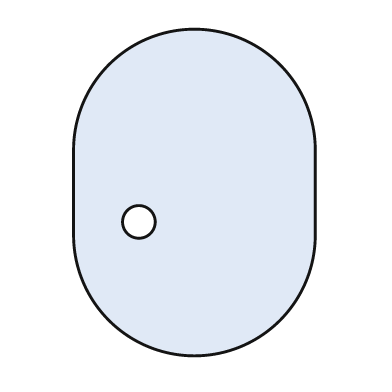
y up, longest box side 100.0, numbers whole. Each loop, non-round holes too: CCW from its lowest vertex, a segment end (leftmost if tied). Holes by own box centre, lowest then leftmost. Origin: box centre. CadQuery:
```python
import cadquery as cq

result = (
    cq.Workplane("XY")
    .moveTo(-37.0, -13.0)
    .threePointArc((0.0, -50.0), (37.0, -13.0))
    .lineTo(37.0, 13.0)
    .threePointArc((0.0, 50.0), (-37.0, 13.0))
    .close()
    .moveTo(-17.0, -9.0)
    .circle(5.0)
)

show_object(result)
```